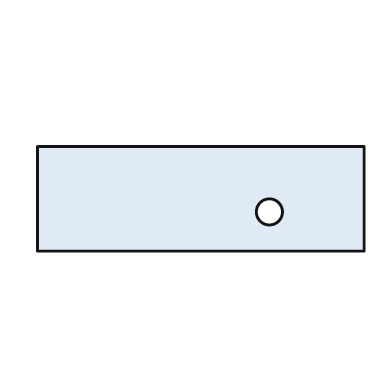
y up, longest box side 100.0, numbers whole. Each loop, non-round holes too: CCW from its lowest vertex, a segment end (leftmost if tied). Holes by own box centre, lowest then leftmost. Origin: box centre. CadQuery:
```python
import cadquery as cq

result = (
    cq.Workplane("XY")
    .moveTo(-50.0, -16.0)
    .lineTo(50.0, -16.0)
    .lineTo(50.0, 16.0)
    .lineTo(-50.0, 16.0)
    .close()
    .moveTo(21.0, -4.0)
    .circle(4.0)
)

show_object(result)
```